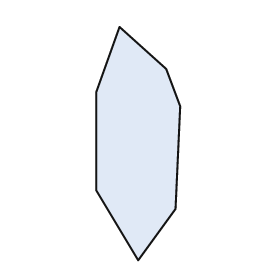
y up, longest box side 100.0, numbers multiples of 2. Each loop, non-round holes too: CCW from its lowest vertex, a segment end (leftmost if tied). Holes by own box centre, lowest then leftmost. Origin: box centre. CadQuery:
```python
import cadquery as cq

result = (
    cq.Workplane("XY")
    .moveTo(0.0, -50.0)
    .lineTo(16.0, -28.0)
    .lineTo(18.0, 16.0)
    .lineTo(12.0, 32.0)
    .lineTo(-8.0, 50.0)
    .lineTo(-18.0, 22.0)
    .lineTo(-18.0, -20.0)
    .close()
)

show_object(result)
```